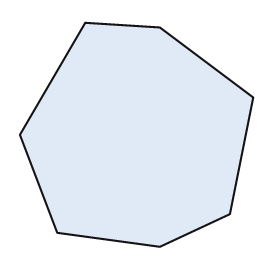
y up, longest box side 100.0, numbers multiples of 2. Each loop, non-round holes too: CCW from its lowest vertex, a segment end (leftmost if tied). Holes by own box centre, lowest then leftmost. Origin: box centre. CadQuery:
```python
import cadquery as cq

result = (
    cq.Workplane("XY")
    .moveTo(10.0, -48.0)
    .lineTo(40.0, -34.0)
    .lineTo(50.0, 16.0)
    .lineTo(10.0, 46.0)
    .lineTo(-22.0, 48.0)
    .lineTo(-50.0, 0.0)
    .lineTo(-34.0, -42.0)
    .close()
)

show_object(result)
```